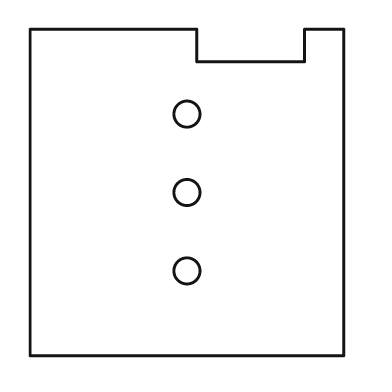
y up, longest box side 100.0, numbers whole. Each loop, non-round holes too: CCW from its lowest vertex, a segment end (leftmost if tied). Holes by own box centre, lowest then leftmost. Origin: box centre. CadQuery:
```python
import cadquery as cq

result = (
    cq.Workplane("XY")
    .moveTo(-48.0, -50.0)
    .lineTo(48.0, -50.0)
    .lineTo(48.0, 50.0)
    .lineTo(36.0, 50.0)
    .lineTo(36.0, 40.0)
    .lineTo(3.0, 40.0)
    .lineTo(3.0, 50.0)
    .lineTo(-48.0, 50.0)
    .close()
    .moveTo(0.0, -24.0)
    .circle(4.0)
    .moveTo(0.0, 0.0)
    .circle(4.0)
    .moveTo(0.0, 24.0)
    .circle(4.0)
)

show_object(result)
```